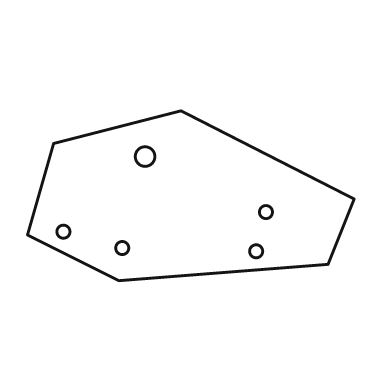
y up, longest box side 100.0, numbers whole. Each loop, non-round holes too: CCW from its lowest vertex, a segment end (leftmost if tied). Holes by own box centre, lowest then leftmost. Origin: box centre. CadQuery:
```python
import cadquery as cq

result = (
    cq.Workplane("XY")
    .moveTo(-22.0, -26.0)
    .lineTo(42.0, -21.0)
    .lineTo(50.0, -1.0)
    .lineTo(-3.0, 26.0)
    .lineTo(-42.0, 16.0)
    .lineTo(-50.0, -12.0)
    .close()
    .moveTo(20.0, -17.0)
    .circle(2.0)
    .moveTo(-21.0, -16.0)
    .circle(2.0)
    .moveTo(-39.0, -11.0)
    .circle(2.0)
    .moveTo(23.0, -5.0)
    .circle(2.0)
    .moveTo(-14.0, 12.0)
    .circle(3.0)
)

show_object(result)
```